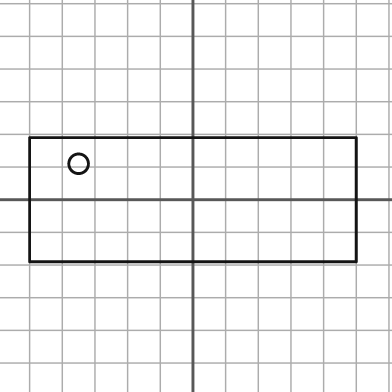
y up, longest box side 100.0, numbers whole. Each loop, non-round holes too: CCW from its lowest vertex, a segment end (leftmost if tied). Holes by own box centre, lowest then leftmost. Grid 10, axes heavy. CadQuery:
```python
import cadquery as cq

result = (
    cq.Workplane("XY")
    .moveTo(-50.0, -19.0)
    .lineTo(50.0, -19.0)
    .lineTo(50.0, 19.0)
    .lineTo(-50.0, 19.0)
    .close()
    .moveTo(-35.0, 11.0)
    .circle(3.0)
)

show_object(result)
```